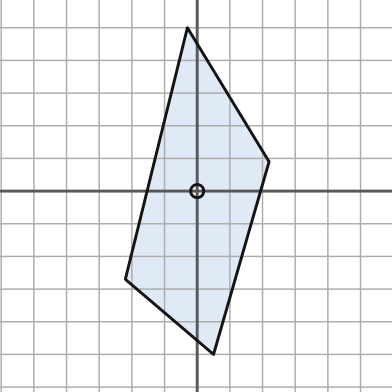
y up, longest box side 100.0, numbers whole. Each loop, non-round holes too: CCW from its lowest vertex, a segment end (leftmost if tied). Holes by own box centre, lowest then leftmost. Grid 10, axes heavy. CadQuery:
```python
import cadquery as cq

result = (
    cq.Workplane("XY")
    .moveTo(5.0, -50.0)
    .lineTo(22.0, 9.0)
    .lineTo(-3.0, 50.0)
    .lineTo(-22.0, -27.0)
    .close()
    .moveTo(0.0, 0.0)
    .circle(2.0)
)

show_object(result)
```